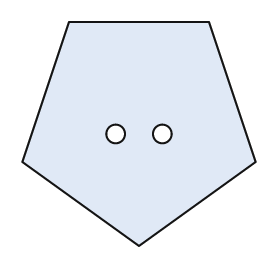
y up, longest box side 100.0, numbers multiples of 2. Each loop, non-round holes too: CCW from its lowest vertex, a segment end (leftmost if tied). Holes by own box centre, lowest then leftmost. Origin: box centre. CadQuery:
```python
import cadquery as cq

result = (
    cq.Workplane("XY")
    .moveTo(0.0, -48.0)
    .lineTo(50.0, -12.0)
    .lineTo(30.0, 48.0)
    .lineTo(-30.0, 48.0)
    .lineTo(-50.0, -12.0)
    .close()
    .moveTo(-10.0, 0.0)
    .circle(4.0)
    .moveTo(10.0, 0.0)
    .circle(4.0)
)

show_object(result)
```